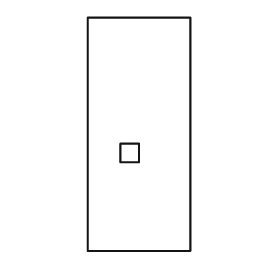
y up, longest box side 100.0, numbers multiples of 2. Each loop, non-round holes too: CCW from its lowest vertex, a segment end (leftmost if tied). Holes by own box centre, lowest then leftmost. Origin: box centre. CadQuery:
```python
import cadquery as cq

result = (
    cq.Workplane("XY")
    .moveTo(-22.0, -50.0)
    .lineTo(22.0, -50.0)
    .lineTo(22.0, 50.0)
    .lineTo(-22.0, 50.0)
    .close()
    .moveTo(-8.0, -12.0)
    .lineTo(0.0, -12.0)
    .lineTo(0.0, -4.0)
    .lineTo(-8.0, -4.0)
    .close()
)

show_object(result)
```